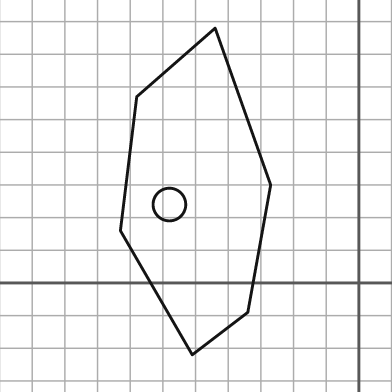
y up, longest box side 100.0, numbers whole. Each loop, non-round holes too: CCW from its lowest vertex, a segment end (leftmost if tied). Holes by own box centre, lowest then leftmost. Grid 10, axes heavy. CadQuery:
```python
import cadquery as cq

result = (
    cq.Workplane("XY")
    .moveTo(-51.0, -22.0)
    .lineTo(-34.0, -9.0)
    .lineTo(-27.0, 30.0)
    .lineTo(-44.0, 78.0)
    .lineTo(-68.0, 57.0)
    .lineTo(-73.0, 16.0)
    .close()
    .moveTo(-58.0, 24.0)
    .circle(5.0)
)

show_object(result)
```